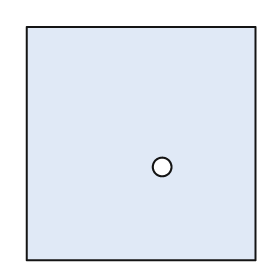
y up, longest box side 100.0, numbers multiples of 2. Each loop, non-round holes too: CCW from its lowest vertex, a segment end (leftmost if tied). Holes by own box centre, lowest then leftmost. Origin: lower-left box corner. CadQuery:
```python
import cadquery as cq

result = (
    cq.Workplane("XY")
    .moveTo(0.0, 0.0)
    .lineTo(98.0, 0.0)
    .lineTo(98.0, 100.0)
    .lineTo(0.0, 100.0)
    .close()
    .moveTo(58.0, 40.0)
    .circle(4.0)
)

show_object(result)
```